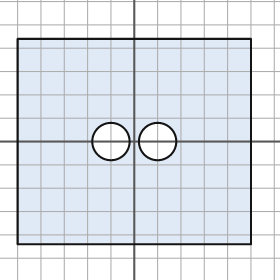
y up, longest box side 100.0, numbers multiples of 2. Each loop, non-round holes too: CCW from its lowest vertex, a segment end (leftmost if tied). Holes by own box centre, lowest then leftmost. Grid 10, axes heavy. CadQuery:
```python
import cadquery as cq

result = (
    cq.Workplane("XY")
    .moveTo(-50.0, -44.0)
    .lineTo(50.0, -44.0)
    .lineTo(50.0, 44.0)
    .lineTo(-50.0, 44.0)
    .close()
    .moveTo(-10.0, 0.0)
    .circle(8.0)
    .moveTo(10.0, 0.0)
    .circle(8.0)
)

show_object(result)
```